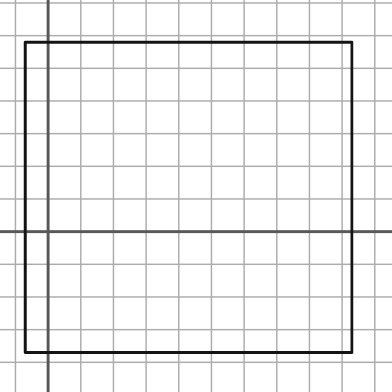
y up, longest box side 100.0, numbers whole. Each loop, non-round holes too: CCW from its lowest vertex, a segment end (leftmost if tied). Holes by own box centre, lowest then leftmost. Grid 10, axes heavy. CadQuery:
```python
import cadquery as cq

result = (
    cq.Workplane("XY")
    .moveTo(-7.0, -37.0)
    .lineTo(93.0, -37.0)
    .lineTo(93.0, 58.0)
    .lineTo(-7.0, 58.0)
    .close()
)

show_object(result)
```